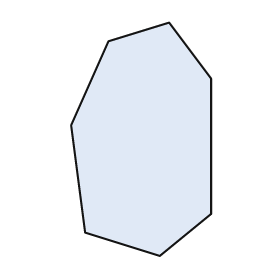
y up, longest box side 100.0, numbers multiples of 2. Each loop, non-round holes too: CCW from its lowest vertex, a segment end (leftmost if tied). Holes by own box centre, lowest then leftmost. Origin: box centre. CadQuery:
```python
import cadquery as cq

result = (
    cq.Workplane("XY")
    .moveTo(8.0, -50.0)
    .lineTo(30.0, -32.0)
    .lineTo(30.0, 26.0)
    .lineTo(12.0, 50.0)
    .lineTo(-14.0, 42.0)
    .lineTo(-30.0, 6.0)
    .lineTo(-24.0, -40.0)
    .close()
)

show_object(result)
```